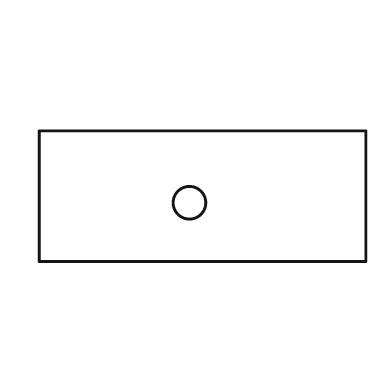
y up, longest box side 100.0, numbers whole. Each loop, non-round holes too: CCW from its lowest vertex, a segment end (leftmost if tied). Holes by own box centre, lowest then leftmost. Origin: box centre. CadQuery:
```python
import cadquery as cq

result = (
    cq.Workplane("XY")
    .moveTo(-50.0, -20.0)
    .lineTo(50.0, -20.0)
    .lineTo(50.0, 20.0)
    .lineTo(-50.0, 20.0)
    .close()
    .moveTo(-4.0, -2.0)
    .circle(5.0)
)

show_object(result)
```